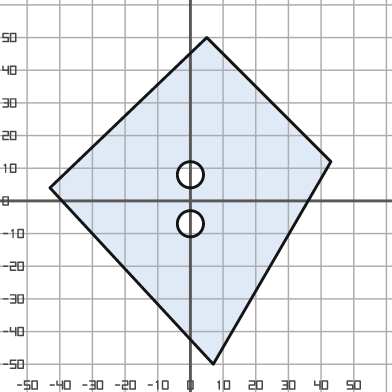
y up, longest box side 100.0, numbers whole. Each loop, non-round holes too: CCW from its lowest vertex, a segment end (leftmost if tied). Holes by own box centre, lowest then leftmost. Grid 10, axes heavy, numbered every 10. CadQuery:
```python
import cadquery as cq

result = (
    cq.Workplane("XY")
    .moveTo(7.0, -50.0)
    .lineTo(43.0, 12.0)
    .lineTo(5.0, 50.0)
    .lineTo(-43.0, 4.0)
    .close()
    .moveTo(0.0, -7.0)
    .circle(4.0)
    .moveTo(0.0, 8.0)
    .circle(4.0)
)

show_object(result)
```